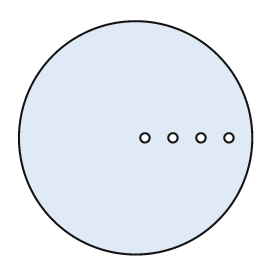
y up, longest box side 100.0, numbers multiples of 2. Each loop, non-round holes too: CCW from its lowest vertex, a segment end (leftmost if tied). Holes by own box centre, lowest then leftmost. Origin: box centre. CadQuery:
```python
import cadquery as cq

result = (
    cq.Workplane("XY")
    .moveTo(0.0, 0.0)
    .circle(50.0)
    .moveTo(4.0, 0.0)
    .circle(2.0)
    .moveTo(16.0, 0.0)
    .circle(2.0)
    .moveTo(28.0, 0.0)
    .circle(2.0)
    .moveTo(40.0, 0.0)
    .circle(2.0)
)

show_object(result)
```